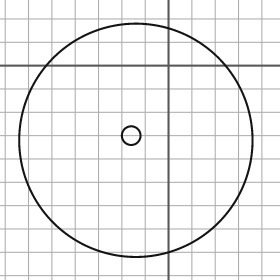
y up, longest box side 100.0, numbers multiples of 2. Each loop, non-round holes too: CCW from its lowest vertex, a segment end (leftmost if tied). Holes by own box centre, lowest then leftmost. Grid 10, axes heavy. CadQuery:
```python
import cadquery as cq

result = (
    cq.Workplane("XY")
    .moveTo(-14.0, -32.0)
    .circle(50.0)
    .moveTo(-16.0, -30.0)
    .circle(4.0)
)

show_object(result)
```